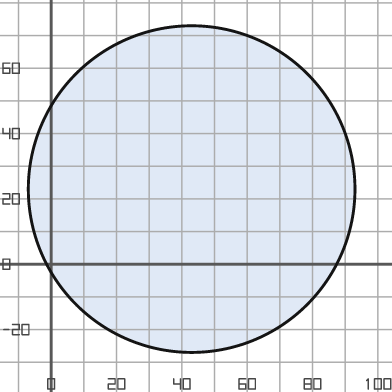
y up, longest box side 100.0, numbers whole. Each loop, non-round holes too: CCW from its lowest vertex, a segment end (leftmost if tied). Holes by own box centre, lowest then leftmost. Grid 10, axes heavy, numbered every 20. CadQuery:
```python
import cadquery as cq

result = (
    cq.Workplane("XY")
    .moveTo(43.0, 23.0)
    .circle(50.0)
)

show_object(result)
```